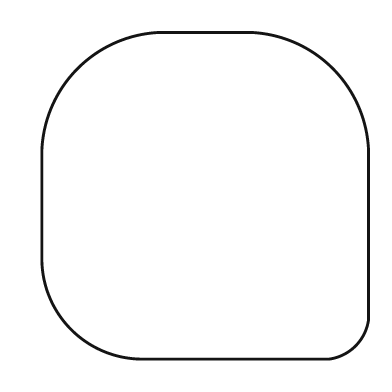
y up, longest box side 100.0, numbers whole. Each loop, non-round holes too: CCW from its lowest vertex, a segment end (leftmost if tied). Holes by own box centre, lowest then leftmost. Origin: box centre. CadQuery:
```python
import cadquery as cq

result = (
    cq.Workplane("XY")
    .moveTo(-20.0, -50.0)
    .lineTo(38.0, -50.0)
    .threePointArc((46.0, -46.0), (50.0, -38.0))
    .lineTo(50.0, 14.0)
    .threePointArc((39.0, 39.0), (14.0, 50.0))
    .lineTo(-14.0, 50.0)
    .threePointArc((-39.0, 39.0), (-50.0, 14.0))
    .lineTo(-50.0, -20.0)
    .threePointArc((-41.0, -41.0), (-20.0, -50.0))
    .close()
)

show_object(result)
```